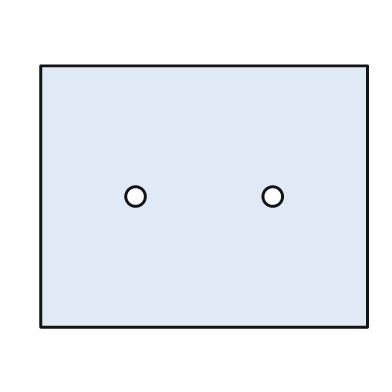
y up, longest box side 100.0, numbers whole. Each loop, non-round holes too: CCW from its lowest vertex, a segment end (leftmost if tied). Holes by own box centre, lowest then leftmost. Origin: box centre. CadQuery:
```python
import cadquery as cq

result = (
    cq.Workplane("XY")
    .moveTo(-50.0, -40.0)
    .lineTo(50.0, -40.0)
    .lineTo(50.0, 40.0)
    .lineTo(-50.0, 40.0)
    .close()
    .moveTo(-21.0, 0.0)
    .circle(3.0)
    .moveTo(21.0, 0.0)
    .circle(3.0)
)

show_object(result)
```